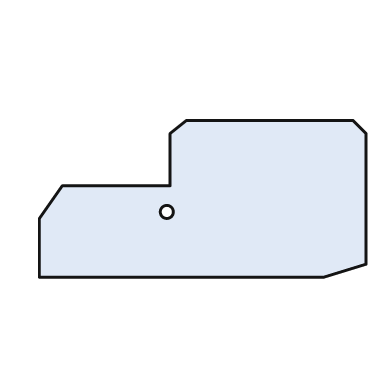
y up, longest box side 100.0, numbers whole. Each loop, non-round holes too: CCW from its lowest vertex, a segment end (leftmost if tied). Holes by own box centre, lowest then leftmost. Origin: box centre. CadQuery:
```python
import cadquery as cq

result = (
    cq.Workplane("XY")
    .moveTo(-50.0, -24.0)
    .lineTo(37.0, -24.0)
    .lineTo(50.0, -20.0)
    .lineTo(50.0, 20.0)
    .lineTo(46.0, 24.0)
    .lineTo(-5.0, 24.0)
    .lineTo(-10.0, 20.0)
    .lineTo(-10.0, 4.0)
    .lineTo(-43.0, 4.0)
    .lineTo(-50.0, -6.0)
    .close()
    .moveTo(-11.0, -4.0)
    .circle(2.0)
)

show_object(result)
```